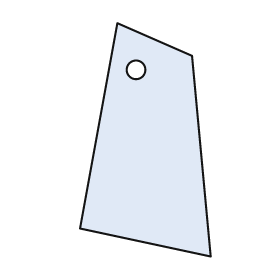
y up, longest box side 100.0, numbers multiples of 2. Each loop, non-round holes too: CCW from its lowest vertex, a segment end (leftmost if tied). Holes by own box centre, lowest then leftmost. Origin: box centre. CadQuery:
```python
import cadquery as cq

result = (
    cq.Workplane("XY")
    .moveTo(28.0, -50.0)
    .lineTo(20.0, 36.0)
    .lineTo(-12.0, 50.0)
    .lineTo(-28.0, -38.0)
    .close()
    .moveTo(-4.0, 30.0)
    .circle(4.0)
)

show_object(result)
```